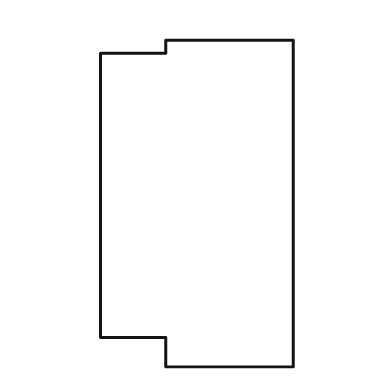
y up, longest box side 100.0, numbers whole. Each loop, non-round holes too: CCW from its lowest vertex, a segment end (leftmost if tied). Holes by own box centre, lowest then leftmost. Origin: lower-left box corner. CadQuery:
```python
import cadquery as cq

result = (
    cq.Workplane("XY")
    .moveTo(20.0, 0.0)
    .lineTo(59.0, 0.0)
    .lineTo(59.0, 100.0)
    .lineTo(20.0, 100.0)
    .lineTo(20.0, 96.0)
    .lineTo(0.0, 96.0)
    .lineTo(0.0, 9.0)
    .lineTo(20.0, 9.0)
    .close()
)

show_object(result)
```